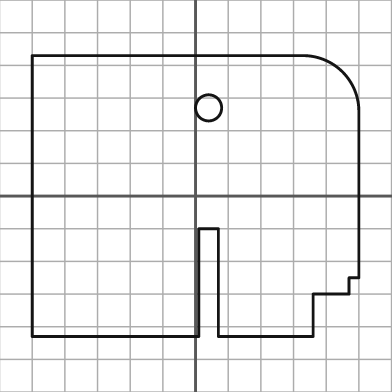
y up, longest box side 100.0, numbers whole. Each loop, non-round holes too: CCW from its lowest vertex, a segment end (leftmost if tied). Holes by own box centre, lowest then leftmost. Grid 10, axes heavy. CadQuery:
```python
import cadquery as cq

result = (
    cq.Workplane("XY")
    .moveTo(-50.0, -43.0)
    .lineTo(1.0, -43.0)
    .lineTo(1.0, -10.0)
    .lineTo(7.0, -10.0)
    .lineTo(7.0, -43.0)
    .lineTo(36.0, -43.0)
    .lineTo(36.0, -30.0)
    .lineTo(47.0, -30.0)
    .lineTo(47.0, -25.0)
    .lineTo(50.0, -25.0)
    .lineTo(50.0, 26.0)
    .threePointArc((45.0, 38.0), (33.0, 43.0))
    .lineTo(-50.0, 43.0)
    .close()
    .moveTo(4.0, 27.0)
    .circle(4.0)
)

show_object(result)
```